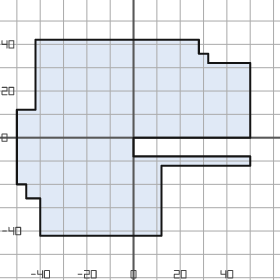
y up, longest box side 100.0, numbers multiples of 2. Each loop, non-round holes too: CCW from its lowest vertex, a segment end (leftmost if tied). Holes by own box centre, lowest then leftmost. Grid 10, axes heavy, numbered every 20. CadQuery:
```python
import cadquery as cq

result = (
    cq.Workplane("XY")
    .moveTo(-40.0, -42.0)
    .lineTo(12.0, -42.0)
    .lineTo(12.0, -12.0)
    .lineTo(50.0, -12.0)
    .lineTo(50.0, -8.0)
    .lineTo(0.0, -8.0)
    .lineTo(0.0, 0.0)
    .lineTo(50.0, 0.0)
    .lineTo(50.0, 32.0)
    .lineTo(32.0, 32.0)
    .lineTo(32.0, 36.0)
    .lineTo(28.0, 36.0)
    .lineTo(28.0, 42.0)
    .lineTo(-42.0, 42.0)
    .lineTo(-42.0, 12.0)
    .lineTo(-50.0, 12.0)
    .lineTo(-50.0, -20.0)
    .lineTo(-46.0, -20.0)
    .lineTo(-46.0, -26.0)
    .lineTo(-40.0, -26.0)
    .close()
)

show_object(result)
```